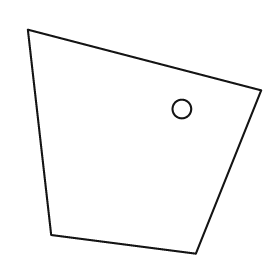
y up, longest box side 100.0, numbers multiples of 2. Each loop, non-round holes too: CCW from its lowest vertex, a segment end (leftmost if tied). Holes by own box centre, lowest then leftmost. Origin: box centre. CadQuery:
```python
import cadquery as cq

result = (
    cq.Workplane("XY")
    .moveTo(22.0, -48.0)
    .lineTo(50.0, 22.0)
    .lineTo(-50.0, 48.0)
    .lineTo(-40.0, -40.0)
    .close()
    .moveTo(16.0, 14.0)
    .circle(4.0)
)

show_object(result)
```